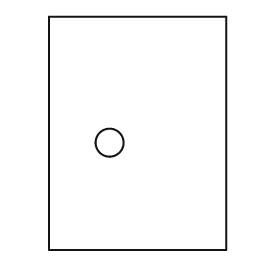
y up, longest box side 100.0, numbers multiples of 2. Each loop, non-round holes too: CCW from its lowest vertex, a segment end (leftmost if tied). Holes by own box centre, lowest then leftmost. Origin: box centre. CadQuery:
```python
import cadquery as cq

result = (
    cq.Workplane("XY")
    .moveTo(-38.0, -50.0)
    .lineTo(38.0, -50.0)
    .lineTo(38.0, 50.0)
    .lineTo(-38.0, 50.0)
    .close()
    .moveTo(-12.0, -4.0)
    .circle(6.0)
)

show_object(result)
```